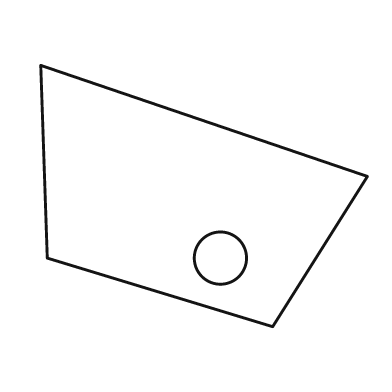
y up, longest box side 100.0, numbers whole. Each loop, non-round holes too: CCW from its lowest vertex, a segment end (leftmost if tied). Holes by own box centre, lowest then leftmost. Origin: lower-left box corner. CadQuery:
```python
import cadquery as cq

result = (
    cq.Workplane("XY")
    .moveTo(71.0, 0.0)
    .lineTo(100.0, 46.0)
    .lineTo(0.0, 80.0)
    .lineTo(2.0, 21.0)
    .close()
    .moveTo(55.0, 21.0)
    .circle(8.0)
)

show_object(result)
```